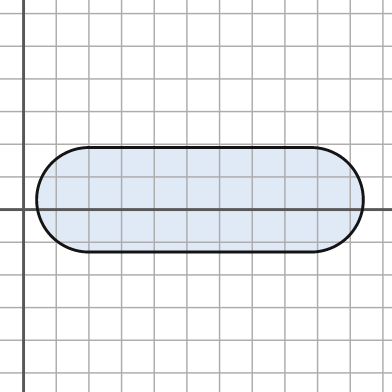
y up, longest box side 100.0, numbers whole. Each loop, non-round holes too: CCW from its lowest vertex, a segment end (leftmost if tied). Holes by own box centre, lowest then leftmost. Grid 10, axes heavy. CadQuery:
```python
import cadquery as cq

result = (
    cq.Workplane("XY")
    .moveTo(20.0, -13.0)
    .lineTo(88.0, -13.0)
    .threePointArc((104.0, 3.0), (88.0, 19.0))
    .lineTo(20.0, 19.0)
    .threePointArc((4.0, 3.0), (20.0, -13.0))
    .close()
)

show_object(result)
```